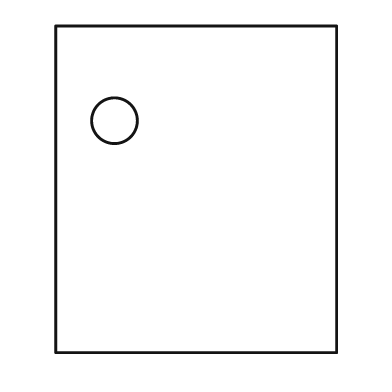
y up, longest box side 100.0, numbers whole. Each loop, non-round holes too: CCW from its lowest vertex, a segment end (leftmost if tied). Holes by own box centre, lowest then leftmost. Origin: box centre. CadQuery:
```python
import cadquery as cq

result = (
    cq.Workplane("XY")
    .moveTo(-43.0, -50.0)
    .lineTo(43.0, -50.0)
    .lineTo(43.0, 50.0)
    .lineTo(-43.0, 50.0)
    .close()
    .moveTo(-25.0, 21.0)
    .circle(7.0)
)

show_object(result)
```